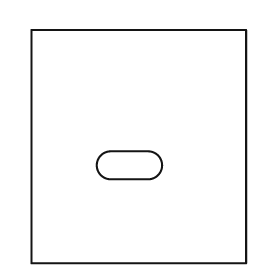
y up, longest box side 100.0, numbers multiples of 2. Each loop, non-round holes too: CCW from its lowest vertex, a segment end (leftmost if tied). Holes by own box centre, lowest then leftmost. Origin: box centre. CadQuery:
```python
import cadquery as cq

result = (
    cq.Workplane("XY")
    .moveTo(-46.0, -50.0)
    .lineTo(46.0, -50.0)
    .lineTo(46.0, 50.0)
    .lineTo(-46.0, 50.0)
    .close()
    .moveTo(-12.0, -14.0)
    .lineTo(4.0, -14.0)
    .threePointArc((10.0, -8.0), (4.0, -2.0))
    .lineTo(-12.0, -2.0)
    .threePointArc((-18.0, -8.0), (-12.0, -14.0))
    .close()
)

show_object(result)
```